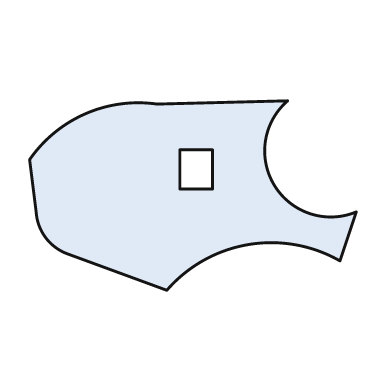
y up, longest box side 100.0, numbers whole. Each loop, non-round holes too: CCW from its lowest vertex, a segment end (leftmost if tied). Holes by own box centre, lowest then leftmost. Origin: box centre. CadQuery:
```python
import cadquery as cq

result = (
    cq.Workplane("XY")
    .moveTo(-8.0, -29.0)
    .threePointArc((17.0, -15.0), (45.0, -20.0))
    .lineTo(50.0, -5.0)
    .threePointArc((25.0, 3.0), (29.0, 29.0))
    .lineTo(-11.0, 28.0)
    .threePointArc((-33.0, 25.0), (-50.0, 11.0))
    .lineTo(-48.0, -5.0)
    .threePointArc((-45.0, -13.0), (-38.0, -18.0))
    .close()
    .moveTo(-4.0, 2.0)
    .lineTo(6.0, 2.0)
    .lineTo(6.0, 14.0)
    .lineTo(-4.0, 14.0)
    .close()
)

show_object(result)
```